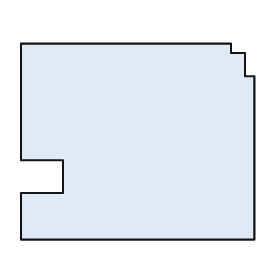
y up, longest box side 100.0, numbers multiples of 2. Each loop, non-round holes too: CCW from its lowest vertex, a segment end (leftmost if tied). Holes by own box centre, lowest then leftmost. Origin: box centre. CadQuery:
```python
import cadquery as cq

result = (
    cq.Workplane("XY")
    .moveTo(-50.0, -42.0)
    .lineTo(50.0, -42.0)
    .lineTo(50.0, 28.0)
    .lineTo(46.0, 28.0)
    .lineTo(46.0, 38.0)
    .lineTo(40.0, 38.0)
    .lineTo(40.0, 42.0)
    .lineTo(-50.0, 42.0)
    .lineTo(-50.0, -8.0)
    .lineTo(-32.0, -8.0)
    .lineTo(-32.0, -22.0)
    .lineTo(-50.0, -22.0)
    .close()
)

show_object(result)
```